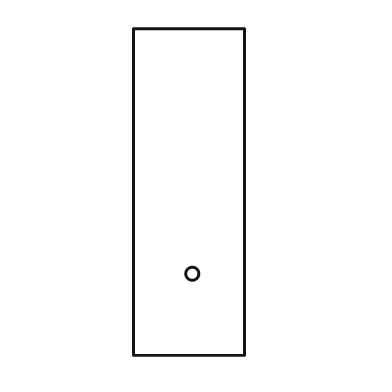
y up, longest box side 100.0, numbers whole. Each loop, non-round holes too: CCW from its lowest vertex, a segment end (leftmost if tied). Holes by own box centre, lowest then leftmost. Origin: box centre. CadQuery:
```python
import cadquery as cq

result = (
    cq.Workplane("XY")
    .moveTo(-17.0, -50.0)
    .lineTo(17.0, -50.0)
    .lineTo(17.0, 50.0)
    .lineTo(-17.0, 50.0)
    .close()
    .moveTo(1.0, -25.0)
    .circle(2.0)
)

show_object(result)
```